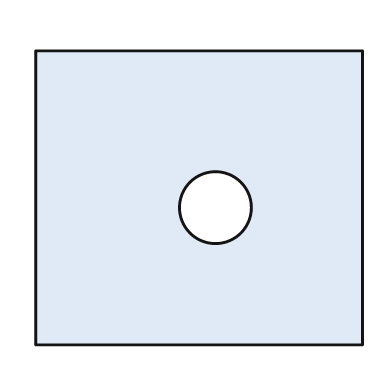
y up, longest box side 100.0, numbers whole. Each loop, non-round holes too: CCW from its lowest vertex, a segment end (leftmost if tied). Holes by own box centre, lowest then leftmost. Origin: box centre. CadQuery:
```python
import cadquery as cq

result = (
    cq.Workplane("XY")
    .moveTo(-50.0, -45.0)
    .lineTo(50.0, -45.0)
    .lineTo(50.0, 45.0)
    .lineTo(-50.0, 45.0)
    .close()
    .moveTo(5.0, -3.0)
    .circle(11.0)
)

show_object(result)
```